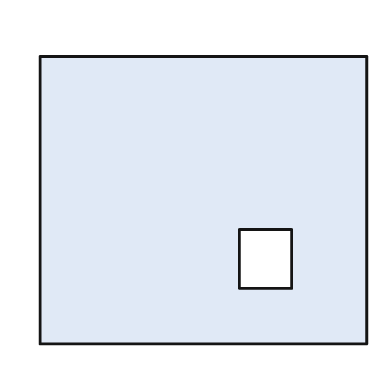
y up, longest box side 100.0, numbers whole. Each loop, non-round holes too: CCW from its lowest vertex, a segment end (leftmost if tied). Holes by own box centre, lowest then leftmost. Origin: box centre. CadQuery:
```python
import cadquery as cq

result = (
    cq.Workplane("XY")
    .moveTo(-50.0, -44.0)
    .lineTo(50.0, -44.0)
    .lineTo(50.0, 44.0)
    .lineTo(-50.0, 44.0)
    .close()
    .moveTo(11.0, -27.0)
    .lineTo(27.0, -27.0)
    .lineTo(27.0, -9.0)
    .lineTo(11.0, -9.0)
    .close()
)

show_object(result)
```